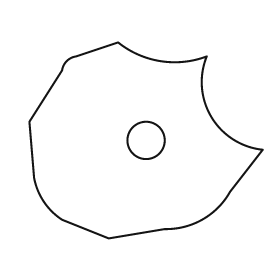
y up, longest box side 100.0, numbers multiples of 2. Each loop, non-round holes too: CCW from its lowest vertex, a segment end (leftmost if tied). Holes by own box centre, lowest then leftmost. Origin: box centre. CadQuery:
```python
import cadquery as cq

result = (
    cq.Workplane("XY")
    .moveTo(-16.0, -42.0)
    .lineTo(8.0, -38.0)
    .threePointArc((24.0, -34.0), (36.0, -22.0))
    .lineTo(50.0, -4.0)
    .threePointArc((28.0, 10.0), (26.0, 36.0))
    .threePointArc((6.0, 34.0), (-12.0, 42.0))
    .lineTo(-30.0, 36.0)
    .threePointArc((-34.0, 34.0), (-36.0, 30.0))
    .lineTo(-50.0, 8.0)
    .lineTo(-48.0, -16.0)
    .threePointArc((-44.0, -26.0), (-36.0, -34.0))
    .close()
    .moveTo(0.0, 0.0)
    .circle(8.0)
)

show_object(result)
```